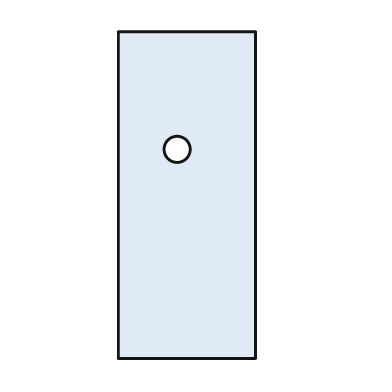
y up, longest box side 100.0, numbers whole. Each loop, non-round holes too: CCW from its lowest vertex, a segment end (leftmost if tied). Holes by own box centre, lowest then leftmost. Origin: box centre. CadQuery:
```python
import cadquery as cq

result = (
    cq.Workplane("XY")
    .moveTo(-21.0, -50.0)
    .lineTo(21.0, -50.0)
    .lineTo(21.0, 50.0)
    .lineTo(-21.0, 50.0)
    .close()
    .moveTo(-3.0, 14.0)
    .circle(4.0)
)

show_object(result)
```